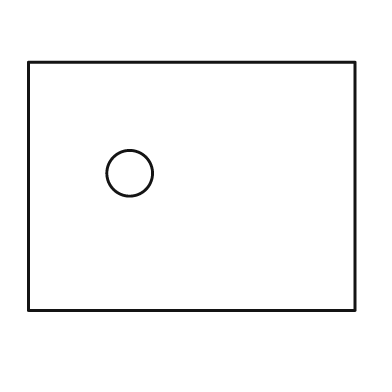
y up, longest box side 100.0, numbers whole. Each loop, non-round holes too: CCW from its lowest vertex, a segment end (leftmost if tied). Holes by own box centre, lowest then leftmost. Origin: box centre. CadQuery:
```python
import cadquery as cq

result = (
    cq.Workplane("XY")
    .moveTo(-50.0, -38.0)
    .lineTo(50.0, -38.0)
    .lineTo(50.0, 38.0)
    .lineTo(-50.0, 38.0)
    .close()
    .moveTo(-19.0, 4.0)
    .circle(7.0)
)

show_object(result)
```